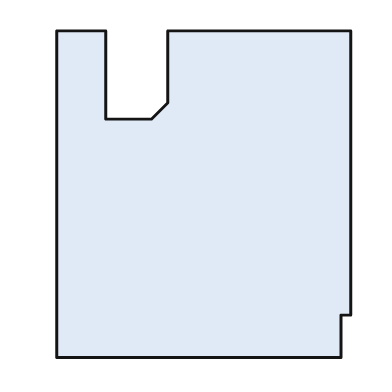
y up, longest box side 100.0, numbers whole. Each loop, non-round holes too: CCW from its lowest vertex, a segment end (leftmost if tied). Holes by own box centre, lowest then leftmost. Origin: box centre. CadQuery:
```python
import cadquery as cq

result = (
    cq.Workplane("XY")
    .moveTo(-45.0, -50.0)
    .lineTo(42.0, -50.0)
    .lineTo(42.0, -37.0)
    .lineTo(45.0, -37.0)
    .lineTo(45.0, 50.0)
    .lineTo(-11.0, 50.0)
    .lineTo(-11.0, 28.0)
    .lineTo(-16.0, 23.0)
    .lineTo(-30.0, 23.0)
    .lineTo(-30.0, 50.0)
    .lineTo(-45.0, 50.0)
    .close()
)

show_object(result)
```